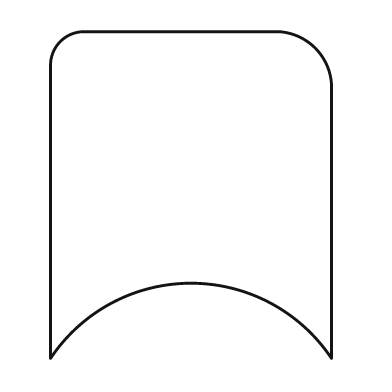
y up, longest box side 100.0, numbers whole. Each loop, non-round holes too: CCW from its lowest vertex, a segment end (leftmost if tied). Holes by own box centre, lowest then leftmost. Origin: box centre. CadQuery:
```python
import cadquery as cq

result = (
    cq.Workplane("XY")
    .moveTo(-43.0, -50.0)
    .threePointArc((0.0, -27.0), (43.0, -50.0))
    .lineTo(43.0, 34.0)
    .threePointArc((38.0, 45.0), (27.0, 50.0))
    .lineTo(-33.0, 50.0)
    .threePointArc((-40.0, 47.0), (-43.0, 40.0))
    .close()
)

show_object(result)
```